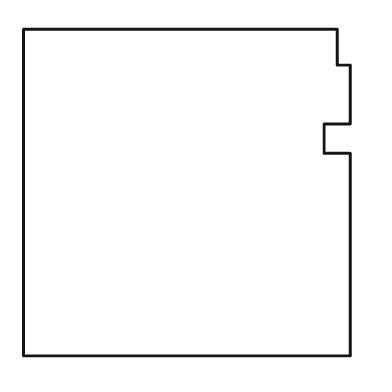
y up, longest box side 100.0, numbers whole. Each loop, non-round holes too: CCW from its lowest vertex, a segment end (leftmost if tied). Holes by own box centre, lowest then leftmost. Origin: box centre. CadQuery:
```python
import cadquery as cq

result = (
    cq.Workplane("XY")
    .moveTo(-50.0, -50.0)
    .lineTo(50.0, -50.0)
    .lineTo(50.0, 12.0)
    .lineTo(42.0, 12.0)
    .lineTo(42.0, 21.0)
    .lineTo(50.0, 21.0)
    .lineTo(50.0, 39.0)
    .lineTo(46.0, 39.0)
    .lineTo(46.0, 50.0)
    .lineTo(-50.0, 50.0)
    .close()
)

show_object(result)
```